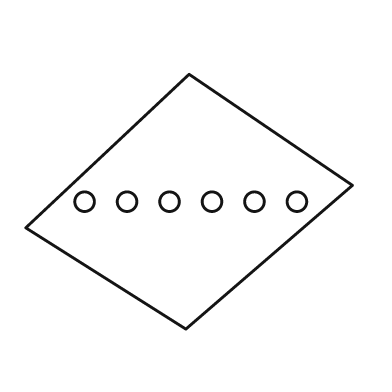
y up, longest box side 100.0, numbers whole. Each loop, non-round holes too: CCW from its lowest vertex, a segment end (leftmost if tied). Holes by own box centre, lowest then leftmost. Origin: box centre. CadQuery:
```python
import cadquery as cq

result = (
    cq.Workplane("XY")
    .moveTo(-1.0, -39.0)
    .lineTo(50.0, 5.0)
    .lineTo(0.0, 39.0)
    .lineTo(-50.0, -8.0)
    .close()
    .moveTo(-32.0, 0.0)
    .circle(3.0)
    .moveTo(-19.0, 0.0)
    .circle(3.0)
    .moveTo(-6.0, 0.0)
    .circle(3.0)
    .moveTo(7.0, 0.0)
    .circle(3.0)
    .moveTo(20.0, 0.0)
    .circle(3.0)
    .moveTo(33.0, 0.0)
    .circle(3.0)
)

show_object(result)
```